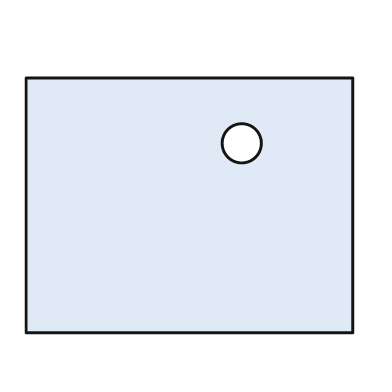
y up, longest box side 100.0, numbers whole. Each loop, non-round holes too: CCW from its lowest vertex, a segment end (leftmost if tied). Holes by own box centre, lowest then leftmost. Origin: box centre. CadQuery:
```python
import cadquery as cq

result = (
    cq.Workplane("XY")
    .moveTo(-50.0, -39.0)
    .lineTo(50.0, -39.0)
    .lineTo(50.0, 39.0)
    .lineTo(-50.0, 39.0)
    .close()
    .moveTo(16.0, 19.0)
    .circle(6.0)
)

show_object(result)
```